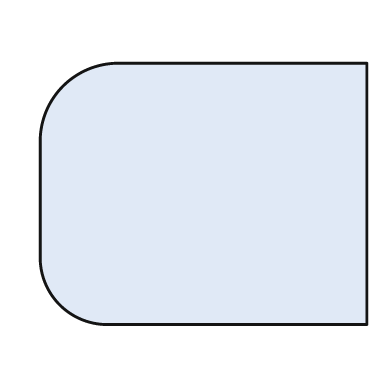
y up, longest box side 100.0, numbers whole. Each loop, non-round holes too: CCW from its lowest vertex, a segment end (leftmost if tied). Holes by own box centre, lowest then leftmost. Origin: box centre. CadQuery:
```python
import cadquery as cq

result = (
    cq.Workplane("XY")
    .moveTo(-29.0, -40.0)
    .lineTo(50.0, -40.0)
    .lineTo(50.0, 40.0)
    .lineTo(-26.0, 40.0)
    .threePointArc((-43.0, 33.0), (-50.0, 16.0))
    .lineTo(-50.0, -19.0)
    .threePointArc((-44.0, -34.0), (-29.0, -40.0))
    .close()
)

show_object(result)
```